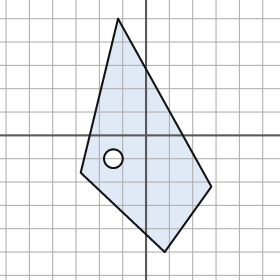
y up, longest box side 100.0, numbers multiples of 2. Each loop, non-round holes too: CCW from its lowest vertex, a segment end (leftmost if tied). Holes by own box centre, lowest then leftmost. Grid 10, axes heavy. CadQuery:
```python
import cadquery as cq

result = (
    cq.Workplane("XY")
    .moveTo(8.0, -50.0)
    .lineTo(28.0, -22.0)
    .lineTo(-12.0, 50.0)
    .lineTo(-28.0, -16.0)
    .close()
    .moveTo(-14.0, -10.0)
    .circle(4.0)
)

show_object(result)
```